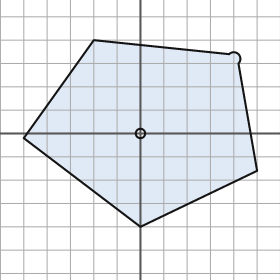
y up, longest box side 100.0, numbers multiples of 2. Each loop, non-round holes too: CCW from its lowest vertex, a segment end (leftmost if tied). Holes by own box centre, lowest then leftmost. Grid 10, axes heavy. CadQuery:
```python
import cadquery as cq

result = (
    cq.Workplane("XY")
    .moveTo(0.0, -40.0)
    .lineTo(50.0, -16.0)
    .lineTo(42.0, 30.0)
    .threePointArc((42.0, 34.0), (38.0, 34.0))
    .lineTo(-20.0, 40.0)
    .lineTo(-50.0, -2.0)
    .close()
    .moveTo(0.0, 0.0)
    .circle(2.0)
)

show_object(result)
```